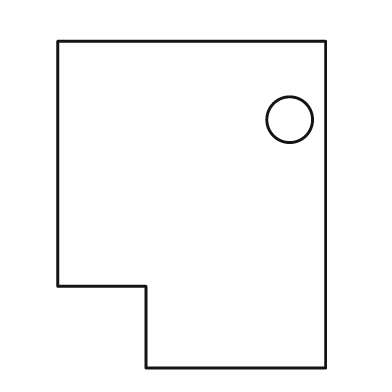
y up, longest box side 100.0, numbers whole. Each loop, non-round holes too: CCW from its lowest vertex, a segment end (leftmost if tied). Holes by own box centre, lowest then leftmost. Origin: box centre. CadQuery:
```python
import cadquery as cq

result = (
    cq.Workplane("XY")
    .moveTo(-14.0, -50.0)
    .lineTo(41.0, -50.0)
    .lineTo(41.0, 50.0)
    .lineTo(-41.0, 50.0)
    .lineTo(-41.0, -25.0)
    .lineTo(-14.0, -25.0)
    .close()
    .moveTo(30.0, 26.0)
    .circle(7.0)
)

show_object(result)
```